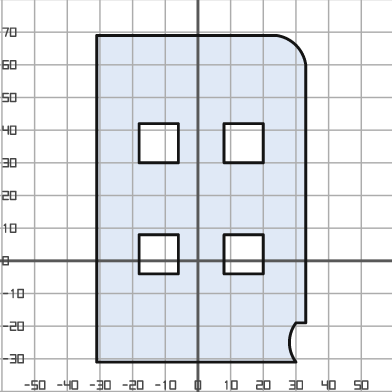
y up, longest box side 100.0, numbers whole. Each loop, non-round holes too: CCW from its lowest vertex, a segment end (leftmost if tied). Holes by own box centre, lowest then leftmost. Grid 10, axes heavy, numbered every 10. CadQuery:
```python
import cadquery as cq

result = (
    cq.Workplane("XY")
    .moveTo(-31.0, -31.0)
    .lineTo(30.0, -31.0)
    .threePointArc((28.0, -25.0), (30.0, -19.0))
    .lineTo(33.0, -19.0)
    .lineTo(33.0, 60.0)
    .threePointArc((30.0, 66.0), (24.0, 69.0))
    .lineTo(-31.0, 69.0)
    .close()
    .moveTo(-18.0, -4.0)
    .lineTo(-6.0, -4.0)
    .lineTo(-6.0, 8.0)
    .lineTo(-18.0, 8.0)
    .close()
    .moveTo(8.0, -4.0)
    .lineTo(20.0, -4.0)
    .lineTo(20.0, 8.0)
    .lineTo(8.0, 8.0)
    .close()
    .moveTo(-18.0, 30.0)
    .lineTo(-6.0, 30.0)
    .lineTo(-6.0, 42.0)
    .lineTo(-18.0, 42.0)
    .close()
    .moveTo(8.0, 30.0)
    .lineTo(20.0, 30.0)
    .lineTo(20.0, 42.0)
    .lineTo(8.0, 42.0)
    .close()
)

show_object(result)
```